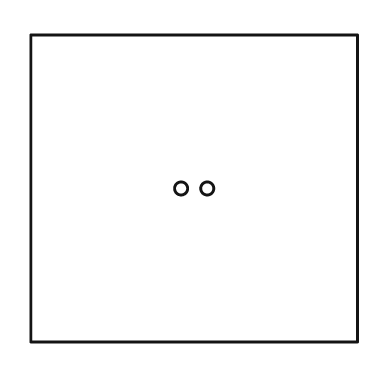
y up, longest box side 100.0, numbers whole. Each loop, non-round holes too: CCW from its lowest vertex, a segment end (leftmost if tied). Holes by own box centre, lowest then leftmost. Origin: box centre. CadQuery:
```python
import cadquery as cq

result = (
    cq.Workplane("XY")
    .moveTo(-50.0, -47.0)
    .lineTo(50.0, -47.0)
    .lineTo(50.0, 47.0)
    .lineTo(-50.0, 47.0)
    .close()
    .moveTo(-4.0, 0.0)
    .circle(2.0)
    .moveTo(4.0, 0.0)
    .circle(2.0)
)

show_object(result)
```